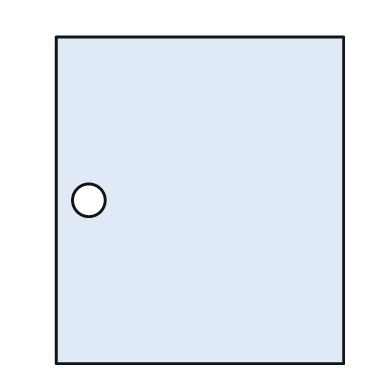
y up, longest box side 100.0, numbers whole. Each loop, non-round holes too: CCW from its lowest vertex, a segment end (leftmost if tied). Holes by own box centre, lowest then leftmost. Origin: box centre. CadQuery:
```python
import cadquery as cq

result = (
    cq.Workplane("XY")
    .moveTo(-44.0, -50.0)
    .lineTo(44.0, -50.0)
    .lineTo(44.0, 50.0)
    .lineTo(-44.0, 50.0)
    .close()
    .moveTo(-34.0, 0.0)
    .circle(5.0)
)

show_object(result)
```